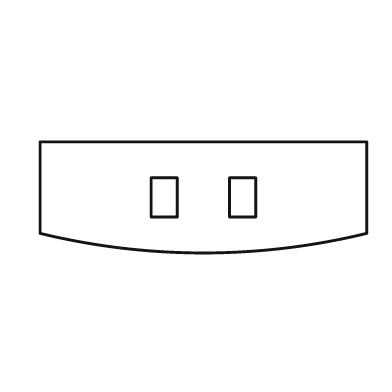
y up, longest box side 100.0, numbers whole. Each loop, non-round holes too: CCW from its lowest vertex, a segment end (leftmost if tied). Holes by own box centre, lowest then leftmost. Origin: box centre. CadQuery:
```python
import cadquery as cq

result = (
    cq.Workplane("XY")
    .moveTo(-50.0, -11.0)
    .threePointArc((0.0, -17.0), (50.0, -11.0))
    .lineTo(50.0, 17.0)
    .lineTo(-50.0, 17.0)
    .close()
    .moveTo(-16.0, -6.0)
    .lineTo(-8.0, -6.0)
    .lineTo(-8.0, 6.0)
    .lineTo(-16.0, 6.0)
    .close()
    .moveTo(8.0, -6.0)
    .lineTo(16.0, -6.0)
    .lineTo(16.0, 6.0)
    .lineTo(8.0, 6.0)
    .close()
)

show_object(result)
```